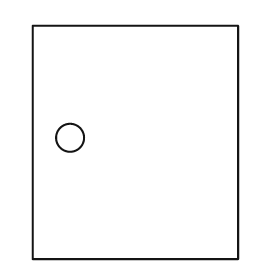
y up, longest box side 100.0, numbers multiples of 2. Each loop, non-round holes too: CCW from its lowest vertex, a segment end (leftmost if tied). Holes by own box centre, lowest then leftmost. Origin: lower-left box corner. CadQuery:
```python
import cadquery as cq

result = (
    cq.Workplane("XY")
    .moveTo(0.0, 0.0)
    .lineTo(88.0, 0.0)
    .lineTo(88.0, 100.0)
    .lineTo(0.0, 100.0)
    .close()
    .moveTo(16.0, 52.0)
    .circle(6.0)
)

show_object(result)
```